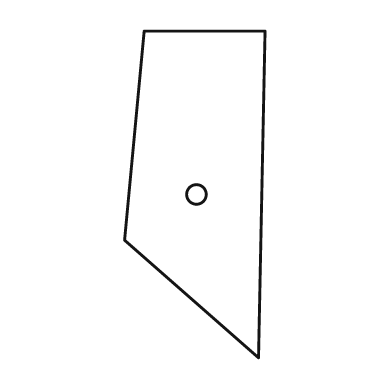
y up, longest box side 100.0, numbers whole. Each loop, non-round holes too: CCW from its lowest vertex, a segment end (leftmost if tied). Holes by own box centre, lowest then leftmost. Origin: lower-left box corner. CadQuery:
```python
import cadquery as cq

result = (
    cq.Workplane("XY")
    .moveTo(41.0, 0.0)
    .lineTo(43.0, 100.0)
    .lineTo(6.0, 100.0)
    .lineTo(0.0, 36.0)
    .close()
    .moveTo(22.0, 50.0)
    .circle(3.0)
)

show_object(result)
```